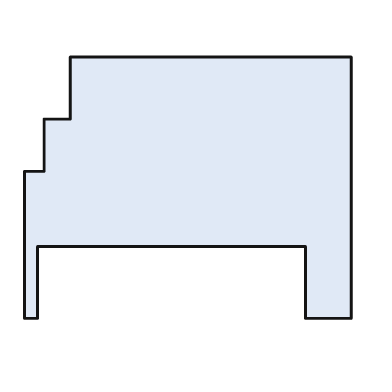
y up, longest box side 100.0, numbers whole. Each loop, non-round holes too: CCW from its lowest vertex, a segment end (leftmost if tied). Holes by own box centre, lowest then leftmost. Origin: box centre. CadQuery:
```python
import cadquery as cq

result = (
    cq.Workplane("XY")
    .moveTo(-50.0, -40.0)
    .lineTo(-46.0, -40.0)
    .lineTo(-46.0, -18.0)
    .lineTo(36.0, -18.0)
    .lineTo(36.0, -40.0)
    .lineTo(50.0, -40.0)
    .lineTo(50.0, 40.0)
    .lineTo(-36.0, 40.0)
    .lineTo(-36.0, 21.0)
    .lineTo(-44.0, 21.0)
    .lineTo(-44.0, 5.0)
    .lineTo(-50.0, 5.0)
    .close()
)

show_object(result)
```